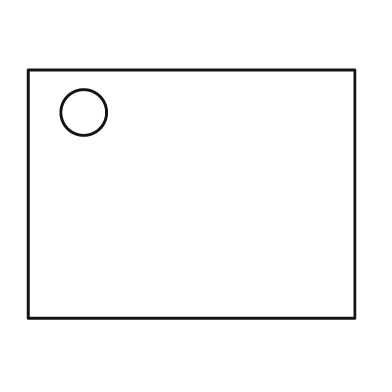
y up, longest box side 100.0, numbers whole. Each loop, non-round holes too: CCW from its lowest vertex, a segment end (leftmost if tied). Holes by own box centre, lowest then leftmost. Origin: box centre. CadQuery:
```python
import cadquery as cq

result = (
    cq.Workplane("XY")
    .moveTo(-50.0, -38.0)
    .lineTo(50.0, -38.0)
    .lineTo(50.0, 38.0)
    .lineTo(-50.0, 38.0)
    .close()
    .moveTo(-33.0, 25.0)
    .circle(7.0)
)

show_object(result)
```